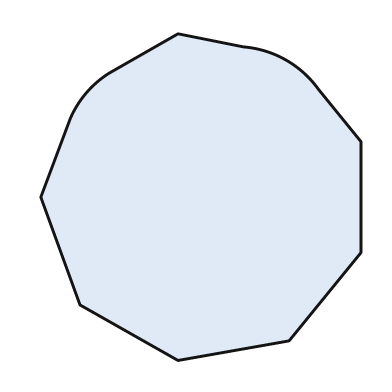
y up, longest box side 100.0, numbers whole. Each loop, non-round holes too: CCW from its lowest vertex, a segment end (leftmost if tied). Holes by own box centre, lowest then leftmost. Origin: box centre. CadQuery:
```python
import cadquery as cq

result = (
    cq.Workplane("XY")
    .moveTo(-7.0, -50.0)
    .lineTo(27.0, -44.0)
    .lineTo(49.0, -17.0)
    .lineTo(49.0, 17.0)
    .lineTo(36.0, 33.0)
    .threePointArc((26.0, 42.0), (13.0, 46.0))
    .lineTo(-7.0, 50.0)
    .lineTo(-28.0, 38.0)
    .threePointArc((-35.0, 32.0), (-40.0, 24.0))
    .lineTo(-49.0, 0.0)
    .lineTo(-37.0, -33.0)
    .close()
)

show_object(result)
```